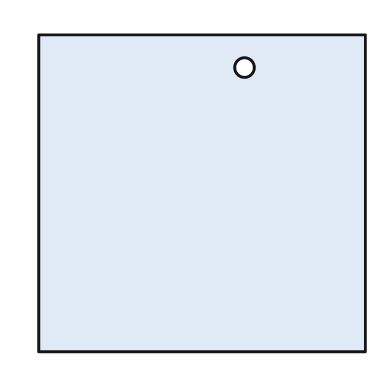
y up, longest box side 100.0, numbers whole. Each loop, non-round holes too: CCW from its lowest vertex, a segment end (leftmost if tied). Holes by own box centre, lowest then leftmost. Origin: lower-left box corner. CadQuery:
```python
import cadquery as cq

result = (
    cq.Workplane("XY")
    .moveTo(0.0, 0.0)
    .lineTo(100.0, 0.0)
    .lineTo(100.0, 97.0)
    .lineTo(0.0, 97.0)
    .close()
    .moveTo(63.0, 87.0)
    .circle(3.0)
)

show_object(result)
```